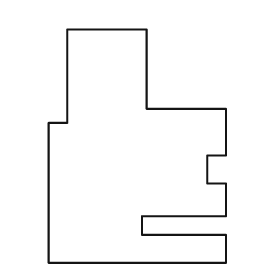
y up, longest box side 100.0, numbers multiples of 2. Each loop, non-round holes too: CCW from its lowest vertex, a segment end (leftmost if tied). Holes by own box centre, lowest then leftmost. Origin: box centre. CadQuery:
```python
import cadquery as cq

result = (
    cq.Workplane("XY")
    .moveTo(-38.0, -50.0)
    .lineTo(38.0, -50.0)
    .lineTo(38.0, -38.0)
    .lineTo(2.0, -38.0)
    .lineTo(2.0, -30.0)
    .lineTo(38.0, -30.0)
    .lineTo(38.0, -16.0)
    .lineTo(30.0, -16.0)
    .lineTo(30.0, -4.0)
    .lineTo(38.0, -4.0)
    .lineTo(38.0, 16.0)
    .lineTo(4.0, 16.0)
    .lineTo(4.0, 50.0)
    .lineTo(-30.0, 50.0)
    .lineTo(-30.0, 10.0)
    .lineTo(-38.0, 10.0)
    .close()
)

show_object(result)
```